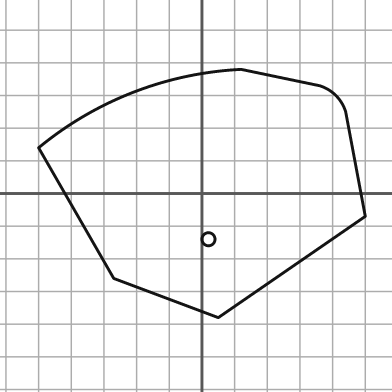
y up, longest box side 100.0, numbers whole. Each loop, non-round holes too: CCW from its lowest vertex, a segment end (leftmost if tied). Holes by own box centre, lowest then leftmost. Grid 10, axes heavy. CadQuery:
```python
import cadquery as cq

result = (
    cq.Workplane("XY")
    .moveTo(5.0, -38.0)
    .lineTo(50.0, -7.0)
    .lineTo(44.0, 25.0)
    .threePointArc((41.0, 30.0), (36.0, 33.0))
    .lineTo(12.0, 38.0)
    .threePointArc((-21.0, 31.0), (-50.0, 14.0))
    .lineTo(-27.0, -26.0)
    .close()
    .moveTo(2.0, -14.0)
    .circle(2.0)
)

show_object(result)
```